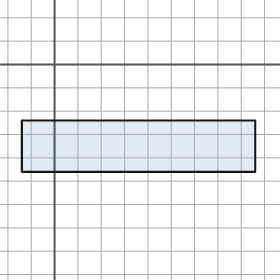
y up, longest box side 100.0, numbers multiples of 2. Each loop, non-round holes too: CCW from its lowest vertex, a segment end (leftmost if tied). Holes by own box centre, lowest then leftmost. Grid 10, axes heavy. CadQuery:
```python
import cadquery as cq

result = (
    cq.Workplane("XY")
    .moveTo(-14.0, -46.0)
    .lineTo(86.0, -46.0)
    .lineTo(86.0, -24.0)
    .lineTo(-14.0, -24.0)
    .close()
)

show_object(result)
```